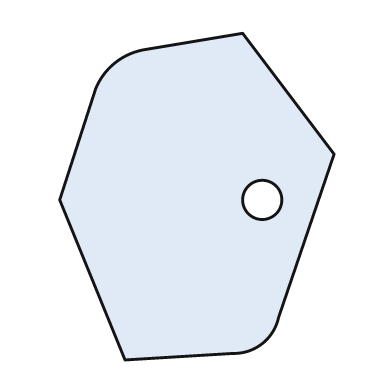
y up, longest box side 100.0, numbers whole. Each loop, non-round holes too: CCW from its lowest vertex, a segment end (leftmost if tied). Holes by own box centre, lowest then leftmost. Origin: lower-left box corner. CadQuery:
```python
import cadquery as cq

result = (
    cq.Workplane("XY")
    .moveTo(20.0, 0.0)
    .lineTo(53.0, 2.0)
    .threePointArc((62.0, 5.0), (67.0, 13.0))
    .lineTo(84.0, 63.0)
    .lineTo(56.0, 100.0)
    .lineTo(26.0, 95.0)
    .threePointArc((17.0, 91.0), (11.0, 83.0))
    .lineTo(0.0, 49.0)
    .close()
    .moveTo(62.0, 49.0)
    .circle(6.0)
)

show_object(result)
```